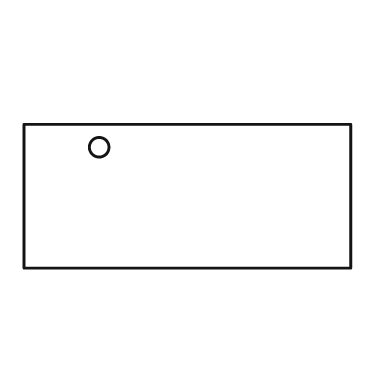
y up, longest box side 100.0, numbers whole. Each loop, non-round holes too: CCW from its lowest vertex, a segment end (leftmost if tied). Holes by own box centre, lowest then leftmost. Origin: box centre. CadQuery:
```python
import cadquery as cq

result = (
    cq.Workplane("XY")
    .moveTo(-50.0, -22.0)
    .lineTo(50.0, -22.0)
    .lineTo(50.0, 22.0)
    .lineTo(-50.0, 22.0)
    .close()
    .moveTo(-27.0, 15.0)
    .circle(3.0)
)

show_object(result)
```